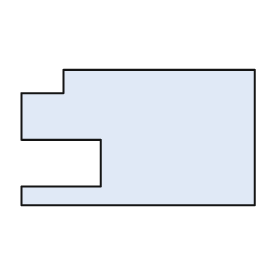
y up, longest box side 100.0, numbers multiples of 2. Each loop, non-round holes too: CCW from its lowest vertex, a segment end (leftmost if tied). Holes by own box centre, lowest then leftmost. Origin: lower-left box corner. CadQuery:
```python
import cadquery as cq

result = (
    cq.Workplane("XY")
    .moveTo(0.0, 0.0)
    .lineTo(100.0, 0.0)
    .lineTo(100.0, 58.0)
    .lineTo(18.0, 58.0)
    .lineTo(18.0, 48.0)
    .lineTo(0.0, 48.0)
    .lineTo(0.0, 28.0)
    .lineTo(34.0, 28.0)
    .lineTo(34.0, 8.0)
    .lineTo(0.0, 8.0)
    .close()
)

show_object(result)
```